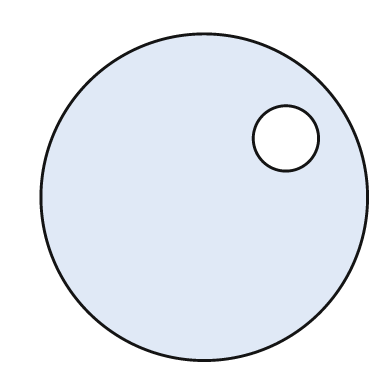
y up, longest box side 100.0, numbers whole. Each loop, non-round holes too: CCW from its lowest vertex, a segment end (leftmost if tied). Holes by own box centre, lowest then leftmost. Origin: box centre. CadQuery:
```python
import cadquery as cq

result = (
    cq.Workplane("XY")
    .moveTo(0.0, 0.0)
    .circle(50.0)
    .moveTo(25.0, 18.0)
    .circle(10.0)
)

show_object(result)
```